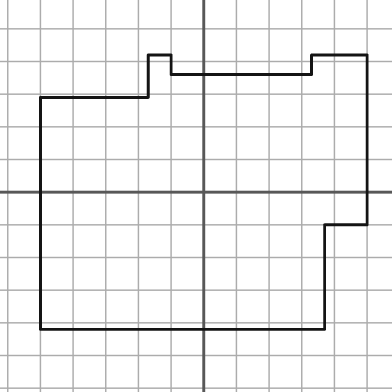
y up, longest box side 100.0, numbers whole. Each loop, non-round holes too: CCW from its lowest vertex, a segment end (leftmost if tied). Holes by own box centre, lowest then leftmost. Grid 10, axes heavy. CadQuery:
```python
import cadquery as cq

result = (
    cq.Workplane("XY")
    .moveTo(-50.0, -42.0)
    .lineTo(37.0, -42.0)
    .lineTo(37.0, -10.0)
    .lineTo(50.0, -10.0)
    .lineTo(50.0, 42.0)
    .lineTo(33.0, 42.0)
    .lineTo(33.0, 36.0)
    .lineTo(-10.0, 36.0)
    .lineTo(-10.0, 42.0)
    .lineTo(-17.0, 42.0)
    .lineTo(-17.0, 29.0)
    .lineTo(-50.0, 29.0)
    .close()
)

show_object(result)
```